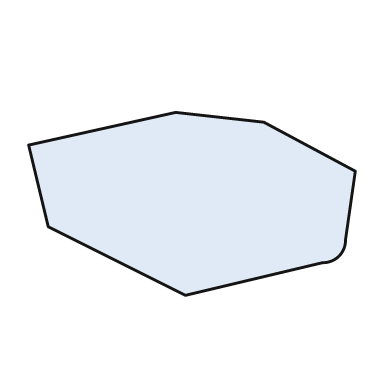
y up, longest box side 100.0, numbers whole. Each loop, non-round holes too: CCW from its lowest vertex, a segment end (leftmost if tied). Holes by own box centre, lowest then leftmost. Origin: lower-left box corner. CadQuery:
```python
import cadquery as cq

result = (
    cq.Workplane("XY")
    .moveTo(48.0, 0.0)
    .lineTo(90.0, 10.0)
    .threePointArc((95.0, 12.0), (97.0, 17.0))
    .lineTo(100.0, 38.0)
    .lineTo(72.0, 53.0)
    .lineTo(45.0, 56.0)
    .lineTo(0.0, 46.0)
    .lineTo(6.0, 21.0)
    .close()
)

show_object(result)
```